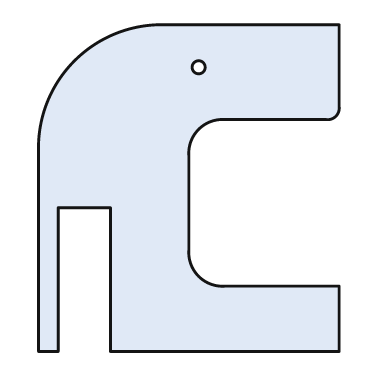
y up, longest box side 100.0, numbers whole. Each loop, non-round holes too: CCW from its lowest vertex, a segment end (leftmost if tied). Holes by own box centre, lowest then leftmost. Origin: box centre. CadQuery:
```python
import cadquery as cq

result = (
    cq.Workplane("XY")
    .moveTo(-46.0, -50.0)
    .lineTo(-40.0, -50.0)
    .lineTo(-40.0, -6.0)
    .lineTo(-24.0, -6.0)
    .lineTo(-24.0, -50.0)
    .lineTo(46.0, -50.0)
    .lineTo(46.0, -30.0)
    .lineTo(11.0, -30.0)
    .threePointArc((3.0, -27.0), (0.0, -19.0))
    .lineTo(0.0, 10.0)
    .threePointArc((3.0, 18.0), (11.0, 21.0))
    .lineTo(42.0, 21.0)
    .threePointArc((45.0, 22.0), (46.0, 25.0))
    .lineTo(46.0, 50.0)
    .lineTo(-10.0, 50.0)
    .threePointArc((-35.0, 39.0), (-46.0, 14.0))
    .close()
    .moveTo(3.0, 37.0)
    .circle(2.0)
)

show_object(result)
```